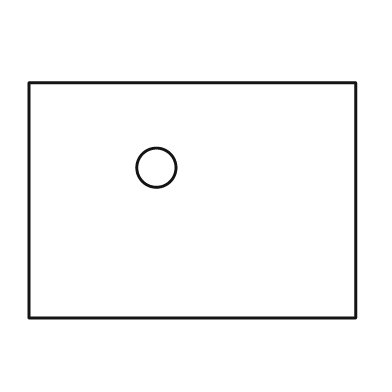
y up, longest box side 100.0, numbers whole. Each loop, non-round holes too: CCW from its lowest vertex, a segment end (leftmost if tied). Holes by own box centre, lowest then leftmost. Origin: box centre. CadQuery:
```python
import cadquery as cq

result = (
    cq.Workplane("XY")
    .moveTo(-50.0, -36.0)
    .lineTo(50.0, -36.0)
    .lineTo(50.0, 36.0)
    .lineTo(-50.0, 36.0)
    .close()
    .moveTo(-11.0, 10.0)
    .circle(6.0)
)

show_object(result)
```